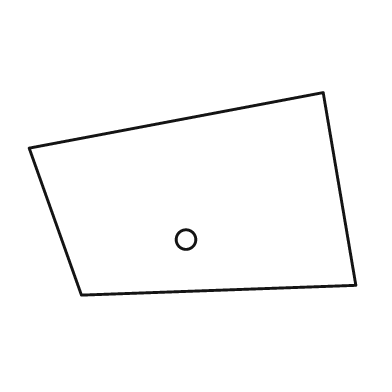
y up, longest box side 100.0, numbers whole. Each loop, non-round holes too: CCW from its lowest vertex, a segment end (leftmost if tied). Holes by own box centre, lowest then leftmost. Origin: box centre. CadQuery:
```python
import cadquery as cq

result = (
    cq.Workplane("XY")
    .moveTo(-34.0, -31.0)
    .lineTo(50.0, -28.0)
    .lineTo(40.0, 31.0)
    .lineTo(-50.0, 14.0)
    .close()
    .moveTo(-2.0, -14.0)
    .circle(3.0)
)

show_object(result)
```